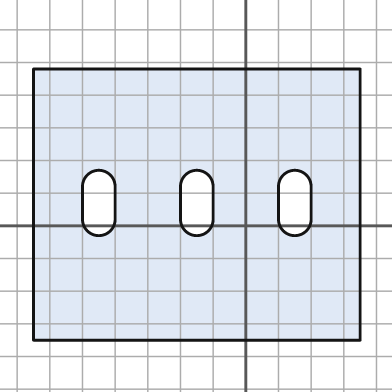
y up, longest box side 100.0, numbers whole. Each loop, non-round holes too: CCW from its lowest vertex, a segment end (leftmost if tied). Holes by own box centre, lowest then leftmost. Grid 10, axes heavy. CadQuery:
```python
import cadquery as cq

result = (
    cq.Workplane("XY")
    .moveTo(-65.0, -35.0)
    .lineTo(35.0, -35.0)
    .lineTo(35.0, 48.0)
    .lineTo(-65.0, 48.0)
    .close()
    .moveTo(-50.0, 2.0)
    .threePointArc((-45.0, -3.0), (-40.0, 2.0))
    .lineTo(-40.0, 12.0)
    .threePointArc((-45.0, 17.0), (-50.0, 12.0))
    .close()
    .moveTo(-20.0, 2.0)
    .threePointArc((-15.0, -3.0), (-10.0, 2.0))
    .lineTo(-10.0, 12.0)
    .threePointArc((-15.0, 17.0), (-20.0, 12.0))
    .close()
    .moveTo(10.0, 2.0)
    .threePointArc((15.0, -3.0), (20.0, 2.0))
    .lineTo(20.0, 12.0)
    .threePointArc((15.0, 17.0), (10.0, 12.0))
    .close()
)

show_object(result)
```